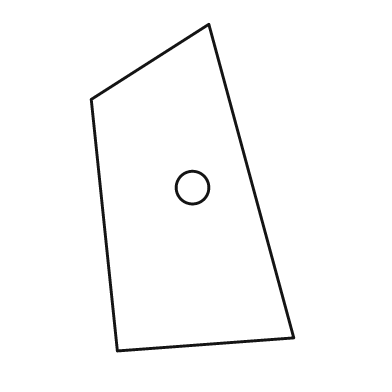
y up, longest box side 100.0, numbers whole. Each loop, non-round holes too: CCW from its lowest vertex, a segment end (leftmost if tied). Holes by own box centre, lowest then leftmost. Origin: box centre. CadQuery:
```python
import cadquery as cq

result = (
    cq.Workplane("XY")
    .moveTo(-23.0, -50.0)
    .lineTo(31.0, -46.0)
    .lineTo(5.0, 50.0)
    .lineTo(-31.0, 27.0)
    .close()
    .moveTo(0.0, 0.0)
    .circle(5.0)
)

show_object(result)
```